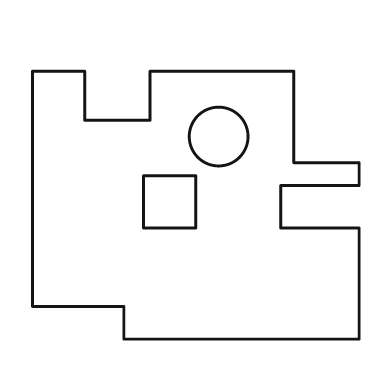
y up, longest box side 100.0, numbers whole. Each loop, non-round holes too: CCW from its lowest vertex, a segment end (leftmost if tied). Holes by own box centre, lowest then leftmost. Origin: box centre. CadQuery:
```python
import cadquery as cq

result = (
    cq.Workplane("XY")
    .moveTo(-22.0, -41.0)
    .lineTo(50.0, -41.0)
    .lineTo(50.0, -7.0)
    .lineTo(26.0, -7.0)
    .lineTo(26.0, 6.0)
    .lineTo(50.0, 6.0)
    .lineTo(50.0, 13.0)
    .lineTo(30.0, 13.0)
    .lineTo(30.0, 41.0)
    .lineTo(-14.0, 41.0)
    .lineTo(-14.0, 26.0)
    .lineTo(-34.0, 26.0)
    .lineTo(-34.0, 41.0)
    .lineTo(-50.0, 41.0)
    .lineTo(-50.0, -31.0)
    .lineTo(-22.0, -31.0)
    .close()
    .moveTo(-16.0, -7.0)
    .lineTo(0.0, -7.0)
    .lineTo(0.0, 9.0)
    .lineTo(-16.0, 9.0)
    .close()
    .moveTo(7.0, 21.0)
    .circle(9.0)
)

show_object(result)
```